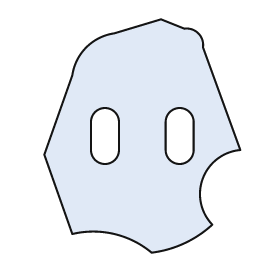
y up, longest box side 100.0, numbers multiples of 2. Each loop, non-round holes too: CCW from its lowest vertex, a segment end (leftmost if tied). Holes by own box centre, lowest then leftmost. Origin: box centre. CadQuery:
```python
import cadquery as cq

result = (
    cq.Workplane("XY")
    .moveTo(4.0, -50.0)
    .threePointArc((18.0, -46.0), (30.0, -38.0))
    .threePointArc((26.0, -18.0), (42.0, -6.0))
    .lineTo(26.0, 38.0)
    .threePointArc((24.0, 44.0), (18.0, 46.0))
    .lineTo(8.0, 50.0)
    .lineTo(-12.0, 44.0)
    .threePointArc((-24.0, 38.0), (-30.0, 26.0))
    .lineTo(-42.0, -8.0)
    .lineTo(-30.0, -42.0)
    .threePointArc((-12.0, -42.0), (4.0, -50.0))
    .close()
    .moveTo(-22.0, -6.0)
    .threePointArc((-16.0, -12.0), (-10.0, -6.0))
    .lineTo(-10.0, 6.0)
    .threePointArc((-16.0, 12.0), (-22.0, 6.0))
    .close()
    .moveTo(10.0, -6.0)
    .threePointArc((16.0, -12.0), (22.0, -6.0))
    .lineTo(22.0, 6.0)
    .threePointArc((16.0, 12.0), (10.0, 6.0))
    .close()
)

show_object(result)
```